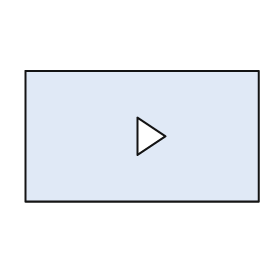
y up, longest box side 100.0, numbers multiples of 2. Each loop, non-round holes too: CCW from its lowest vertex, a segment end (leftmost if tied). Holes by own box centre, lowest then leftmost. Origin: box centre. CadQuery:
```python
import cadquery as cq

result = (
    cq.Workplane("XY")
    .moveTo(-50.0, -28.0)
    .lineTo(50.0, -28.0)
    .lineTo(50.0, 28.0)
    .lineTo(-50.0, 28.0)
    .close()
    .moveTo(-2.0, -8.0)
    .lineTo(10.0, 0.0)
    .lineTo(-2.0, 8.0)
    .close()
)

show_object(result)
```